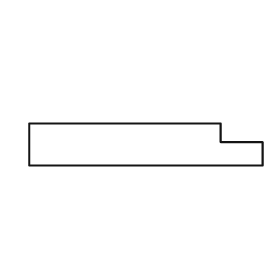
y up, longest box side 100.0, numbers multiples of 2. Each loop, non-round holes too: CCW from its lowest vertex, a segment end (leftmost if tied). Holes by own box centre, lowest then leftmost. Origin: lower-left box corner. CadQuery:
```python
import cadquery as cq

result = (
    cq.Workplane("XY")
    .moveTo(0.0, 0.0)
    .lineTo(100.0, 0.0)
    .lineTo(100.0, 10.0)
    .lineTo(82.0, 10.0)
    .lineTo(82.0, 18.0)
    .lineTo(0.0, 18.0)
    .close()
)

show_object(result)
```